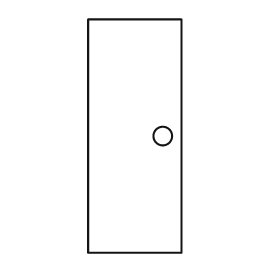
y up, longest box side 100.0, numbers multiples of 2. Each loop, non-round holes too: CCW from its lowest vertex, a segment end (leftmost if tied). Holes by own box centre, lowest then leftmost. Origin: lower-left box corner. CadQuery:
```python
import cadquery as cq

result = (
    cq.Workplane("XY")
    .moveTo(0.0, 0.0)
    .lineTo(40.0, 0.0)
    .lineTo(40.0, 100.0)
    .lineTo(0.0, 100.0)
    .close()
    .moveTo(32.0, 50.0)
    .circle(4.0)
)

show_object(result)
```